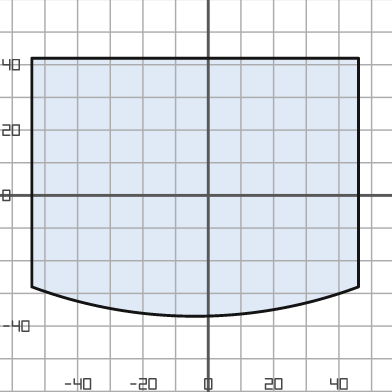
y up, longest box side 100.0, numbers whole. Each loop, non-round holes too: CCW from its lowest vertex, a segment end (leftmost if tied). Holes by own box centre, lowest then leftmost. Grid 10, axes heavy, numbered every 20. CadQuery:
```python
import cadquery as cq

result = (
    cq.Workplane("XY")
    .moveTo(-54.0, -28.0)
    .threePointArc((-4.0, -37.0), (46.0, -28.0))
    .lineTo(46.0, 42.0)
    .lineTo(-54.0, 42.0)
    .close()
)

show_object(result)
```